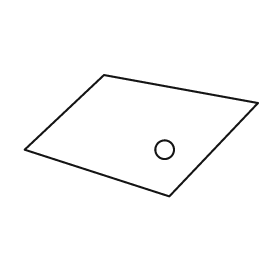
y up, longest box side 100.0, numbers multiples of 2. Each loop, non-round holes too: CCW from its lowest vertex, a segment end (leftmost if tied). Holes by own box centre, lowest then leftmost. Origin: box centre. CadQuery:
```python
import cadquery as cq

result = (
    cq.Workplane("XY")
    .moveTo(12.0, -26.0)
    .lineTo(50.0, 14.0)
    .lineTo(-16.0, 26.0)
    .lineTo(-50.0, -6.0)
    .close()
    .moveTo(10.0, -6.0)
    .circle(4.0)
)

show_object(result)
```